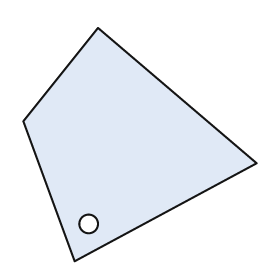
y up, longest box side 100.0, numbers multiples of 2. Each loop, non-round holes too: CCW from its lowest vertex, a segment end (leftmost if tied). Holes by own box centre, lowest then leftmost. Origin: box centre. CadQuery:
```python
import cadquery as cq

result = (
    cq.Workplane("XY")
    .moveTo(-28.0, -50.0)
    .lineTo(50.0, -8.0)
    .lineTo(-18.0, 50.0)
    .lineTo(-50.0, 10.0)
    .close()
    .moveTo(-22.0, -34.0)
    .circle(4.0)
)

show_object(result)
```